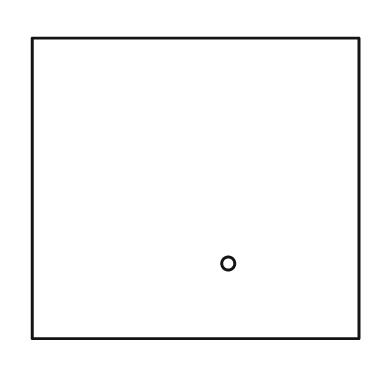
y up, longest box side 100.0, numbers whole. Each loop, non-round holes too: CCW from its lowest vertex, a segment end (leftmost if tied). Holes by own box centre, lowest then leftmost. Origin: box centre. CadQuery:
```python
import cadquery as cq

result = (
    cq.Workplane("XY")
    .moveTo(-50.0, -46.0)
    .lineTo(50.0, -46.0)
    .lineTo(50.0, 46.0)
    .lineTo(-50.0, 46.0)
    .close()
    .moveTo(10.0, -23.0)
    .circle(2.0)
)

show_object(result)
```